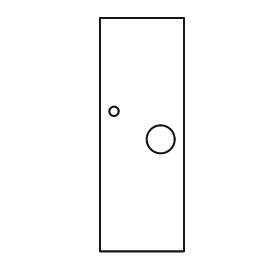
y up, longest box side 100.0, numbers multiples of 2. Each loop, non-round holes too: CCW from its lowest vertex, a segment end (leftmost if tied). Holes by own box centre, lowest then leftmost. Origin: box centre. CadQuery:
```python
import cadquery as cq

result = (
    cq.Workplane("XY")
    .moveTo(-18.0, -50.0)
    .lineTo(18.0, -50.0)
    .lineTo(18.0, 50.0)
    .lineTo(-18.0, 50.0)
    .close()
    .moveTo(8.0, -2.0)
    .circle(6.0)
    .moveTo(-12.0, 10.0)
    .circle(2.0)
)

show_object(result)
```